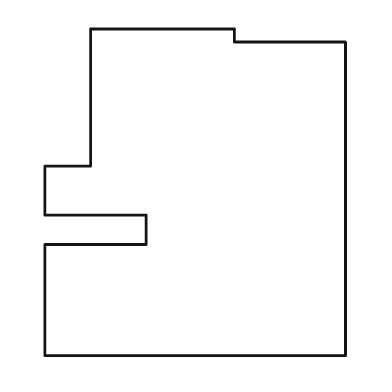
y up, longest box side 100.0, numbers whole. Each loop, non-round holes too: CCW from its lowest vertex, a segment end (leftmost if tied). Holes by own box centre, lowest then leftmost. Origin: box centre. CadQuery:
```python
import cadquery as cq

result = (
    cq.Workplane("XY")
    .moveTo(-46.0, -50.0)
    .lineTo(46.0, -50.0)
    .lineTo(46.0, 46.0)
    .lineTo(12.0, 46.0)
    .lineTo(12.0, 50.0)
    .lineTo(-32.0, 50.0)
    .lineTo(-32.0, 8.0)
    .lineTo(-46.0, 8.0)
    .lineTo(-46.0, -7.0)
    .lineTo(-15.0, -7.0)
    .lineTo(-15.0, -16.0)
    .lineTo(-46.0, -16.0)
    .close()
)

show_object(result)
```